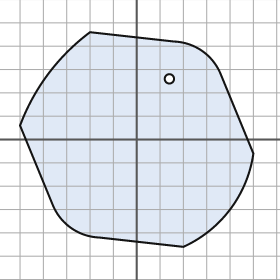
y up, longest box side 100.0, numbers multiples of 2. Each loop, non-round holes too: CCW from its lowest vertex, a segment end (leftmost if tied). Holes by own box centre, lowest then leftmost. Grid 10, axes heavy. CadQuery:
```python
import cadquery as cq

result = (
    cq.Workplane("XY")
    .moveTo(20.0, -46.0)
    .threePointArc((40.0, -30.0), (50.0, -6.0))
    .lineTo(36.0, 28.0)
    .threePointArc((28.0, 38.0), (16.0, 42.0))
    .lineTo(-20.0, 46.0)
    .threePointArc((-38.0, 28.0), (-50.0, 6.0))
    .lineTo(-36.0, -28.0)
    .threePointArc((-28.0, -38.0), (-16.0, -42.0))
    .close()
    .moveTo(14.0, 26.0)
    .circle(2.0)
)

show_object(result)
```